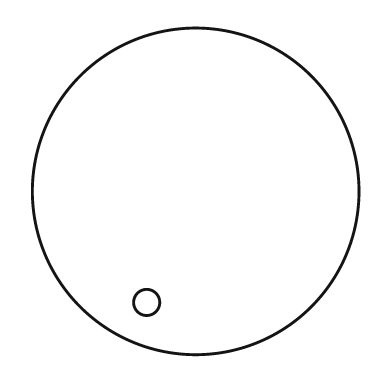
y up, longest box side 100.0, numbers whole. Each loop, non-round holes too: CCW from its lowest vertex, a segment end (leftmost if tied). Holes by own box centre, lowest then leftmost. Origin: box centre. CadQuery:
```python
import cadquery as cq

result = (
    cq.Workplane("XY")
    .moveTo(0.0, 0.0)
    .circle(50.0)
    .moveTo(-15.0, -34.0)
    .circle(4.0)
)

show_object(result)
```